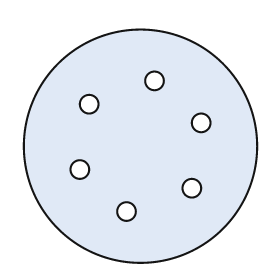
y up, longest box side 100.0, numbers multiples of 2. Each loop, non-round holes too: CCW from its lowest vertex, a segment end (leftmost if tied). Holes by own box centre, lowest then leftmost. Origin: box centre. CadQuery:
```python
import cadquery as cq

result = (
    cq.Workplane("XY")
    .moveTo(0.0, 0.0)
    .circle(50.0)
    .moveTo(-6.0, -28.0)
    .circle(4.0)
    .moveTo(22.0, -18.0)
    .circle(4.0)
    .moveTo(-26.0, -10.0)
    .circle(4.0)
    .moveTo(26.0, 10.0)
    .circle(4.0)
    .moveTo(-22.0, 18.0)
    .circle(4.0)
    .moveTo(6.0, 28.0)
    .circle(4.0)
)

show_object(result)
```